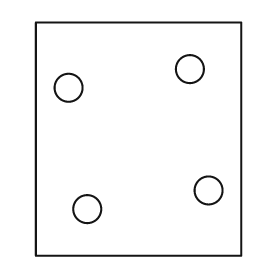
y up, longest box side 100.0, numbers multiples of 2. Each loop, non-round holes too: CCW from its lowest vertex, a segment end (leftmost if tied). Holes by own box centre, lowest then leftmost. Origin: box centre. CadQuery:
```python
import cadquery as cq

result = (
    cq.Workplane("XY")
    .moveTo(-44.0, -50.0)
    .lineTo(44.0, -50.0)
    .lineTo(44.0, 50.0)
    .lineTo(-44.0, 50.0)
    .close()
    .moveTo(-22.0, -30.0)
    .circle(6.0)
    .moveTo(30.0, -22.0)
    .circle(6.0)
    .moveTo(-30.0, 22.0)
    .circle(6.0)
    .moveTo(22.0, 30.0)
    .circle(6.0)
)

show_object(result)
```